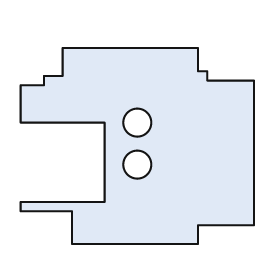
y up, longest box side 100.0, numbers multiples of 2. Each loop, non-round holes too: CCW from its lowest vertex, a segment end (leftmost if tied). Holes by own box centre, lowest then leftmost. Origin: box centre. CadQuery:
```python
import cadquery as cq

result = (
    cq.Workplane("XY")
    .moveTo(-28.0, -42.0)
    .lineTo(26.0, -42.0)
    .lineTo(26.0, -34.0)
    .lineTo(50.0, -34.0)
    .lineTo(50.0, 28.0)
    .lineTo(30.0, 28.0)
    .lineTo(30.0, 32.0)
    .lineTo(26.0, 32.0)
    .lineTo(26.0, 42.0)
    .lineTo(-32.0, 42.0)
    .lineTo(-32.0, 30.0)
    .lineTo(-40.0, 30.0)
    .lineTo(-40.0, 26.0)
    .lineTo(-50.0, 26.0)
    .lineTo(-50.0, 10.0)
    .lineTo(-14.0, 10.0)
    .lineTo(-14.0, -24.0)
    .lineTo(-50.0, -24.0)
    .lineTo(-50.0, -28.0)
    .lineTo(-28.0, -28.0)
    .close()
    .moveTo(0.0, -8.0)
    .circle(6.0)
    .moveTo(0.0, 10.0)
    .circle(6.0)
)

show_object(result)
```